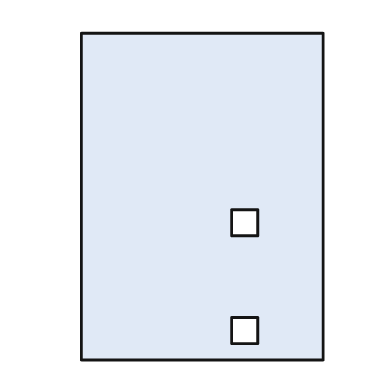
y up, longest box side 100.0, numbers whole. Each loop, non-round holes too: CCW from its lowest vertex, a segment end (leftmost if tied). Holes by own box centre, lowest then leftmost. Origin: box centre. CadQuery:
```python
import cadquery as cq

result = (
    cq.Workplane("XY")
    .moveTo(-37.0, -50.0)
    .lineTo(37.0, -50.0)
    .lineTo(37.0, 50.0)
    .lineTo(-37.0, 50.0)
    .close()
    .moveTo(9.0, -45.0)
    .lineTo(17.0, -45.0)
    .lineTo(17.0, -37.0)
    .lineTo(9.0, -37.0)
    .close()
    .moveTo(9.0, -12.0)
    .lineTo(17.0, -12.0)
    .lineTo(17.0, -4.0)
    .lineTo(9.0, -4.0)
    .close()
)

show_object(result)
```